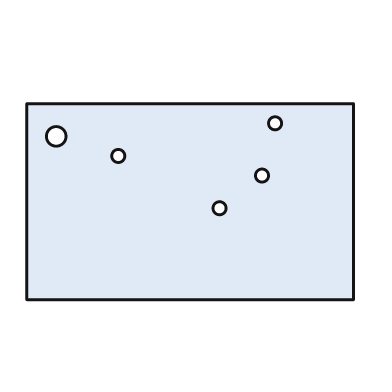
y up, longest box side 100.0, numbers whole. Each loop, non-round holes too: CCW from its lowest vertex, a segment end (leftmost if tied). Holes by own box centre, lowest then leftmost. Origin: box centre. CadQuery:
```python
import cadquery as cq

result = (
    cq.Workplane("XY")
    .moveTo(-50.0, -30.0)
    .lineTo(50.0, -30.0)
    .lineTo(50.0, 30.0)
    .lineTo(-50.0, 30.0)
    .close()
    .moveTo(9.0, -2.0)
    .circle(2.0)
    .moveTo(22.0, 8.0)
    .circle(2.0)
    .moveTo(-22.0, 14.0)
    .circle(2.0)
    .moveTo(-41.0, 20.0)
    .circle(3.0)
    .moveTo(26.0, 24.0)
    .circle(2.0)
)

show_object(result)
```